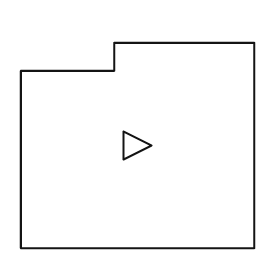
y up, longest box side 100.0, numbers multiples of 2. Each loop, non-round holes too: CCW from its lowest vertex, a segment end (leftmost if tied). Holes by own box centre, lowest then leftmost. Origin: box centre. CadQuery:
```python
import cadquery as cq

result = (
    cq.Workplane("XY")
    .moveTo(-50.0, -44.0)
    .lineTo(50.0, -44.0)
    .lineTo(50.0, 44.0)
    .lineTo(-10.0, 44.0)
    .lineTo(-10.0, 32.0)
    .lineTo(-50.0, 32.0)
    .close()
    .moveTo(-6.0, -6.0)
    .lineTo(6.0, 0.0)
    .lineTo(-6.0, 6.0)
    .close()
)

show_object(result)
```